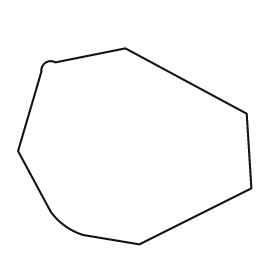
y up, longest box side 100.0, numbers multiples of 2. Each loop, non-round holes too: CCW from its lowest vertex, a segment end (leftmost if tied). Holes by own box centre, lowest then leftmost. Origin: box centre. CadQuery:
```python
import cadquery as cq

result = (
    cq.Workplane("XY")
    .moveTo(2.0, -42.0)
    .lineTo(50.0, -18.0)
    .lineTo(48.0, 14.0)
    .lineTo(-4.0, 42.0)
    .lineTo(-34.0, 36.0)
    .threePointArc((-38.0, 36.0), (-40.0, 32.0))
    .lineTo(-50.0, -2.0)
    .lineTo(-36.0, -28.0)
    .threePointArc((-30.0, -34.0), (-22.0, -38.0))
    .close()
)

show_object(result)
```